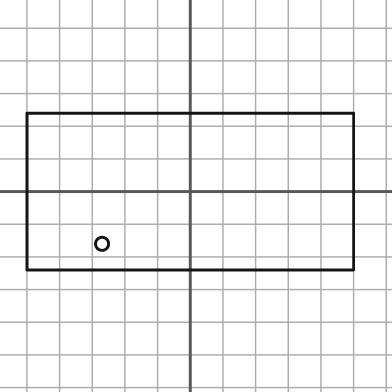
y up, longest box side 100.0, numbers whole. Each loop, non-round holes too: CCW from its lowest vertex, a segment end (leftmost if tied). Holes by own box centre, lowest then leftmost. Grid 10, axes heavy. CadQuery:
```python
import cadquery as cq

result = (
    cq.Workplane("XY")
    .moveTo(-50.0, -24.0)
    .lineTo(50.0, -24.0)
    .lineTo(50.0, 24.0)
    .lineTo(-50.0, 24.0)
    .close()
    .moveTo(-27.0, -16.0)
    .circle(2.0)
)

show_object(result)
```